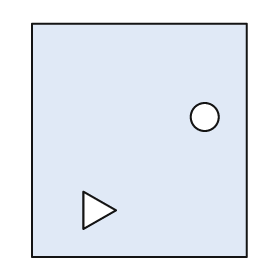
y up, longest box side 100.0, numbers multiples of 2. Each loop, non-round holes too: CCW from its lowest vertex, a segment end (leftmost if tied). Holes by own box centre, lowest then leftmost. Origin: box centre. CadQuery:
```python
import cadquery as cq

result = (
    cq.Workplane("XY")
    .moveTo(-46.0, -50.0)
    .lineTo(46.0, -50.0)
    .lineTo(46.0, 50.0)
    .lineTo(-46.0, 50.0)
    .close()
    .moveTo(-24.0, -38.0)
    .lineTo(-10.0, -30.0)
    .lineTo(-24.0, -22.0)
    .close()
    .moveTo(28.0, 10.0)
    .circle(6.0)
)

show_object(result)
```